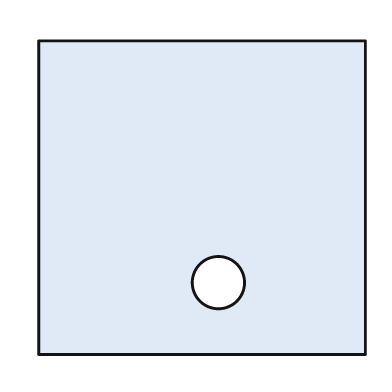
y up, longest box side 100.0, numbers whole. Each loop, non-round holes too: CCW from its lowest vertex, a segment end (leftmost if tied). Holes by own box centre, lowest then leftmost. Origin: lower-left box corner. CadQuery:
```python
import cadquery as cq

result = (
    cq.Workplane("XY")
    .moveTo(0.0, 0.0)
    .lineTo(100.0, 0.0)
    .lineTo(100.0, 96.0)
    .lineTo(0.0, 96.0)
    .close()
    .moveTo(55.0, 22.0)
    .circle(8.0)
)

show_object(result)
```